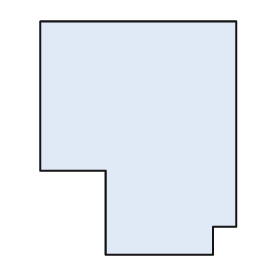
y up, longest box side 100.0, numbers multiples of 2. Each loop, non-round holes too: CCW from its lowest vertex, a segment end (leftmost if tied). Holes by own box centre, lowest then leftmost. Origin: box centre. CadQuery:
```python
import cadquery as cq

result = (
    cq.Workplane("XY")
    .moveTo(-14.0, -50.0)
    .lineTo(32.0, -50.0)
    .lineTo(32.0, -38.0)
    .lineTo(42.0, -38.0)
    .lineTo(42.0, 50.0)
    .lineTo(-42.0, 50.0)
    .lineTo(-42.0, -14.0)
    .lineTo(-14.0, -14.0)
    .close()
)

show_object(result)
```